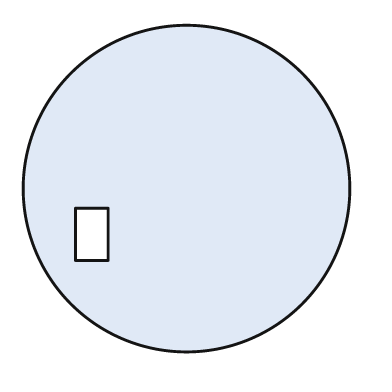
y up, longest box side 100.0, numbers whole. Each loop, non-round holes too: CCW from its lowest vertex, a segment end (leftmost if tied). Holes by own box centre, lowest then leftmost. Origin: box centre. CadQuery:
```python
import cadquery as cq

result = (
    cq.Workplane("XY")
    .moveTo(0.0, 0.0)
    .circle(50.0)
    .moveTo(-34.0, -22.0)
    .lineTo(-24.0, -22.0)
    .lineTo(-24.0, -6.0)
    .lineTo(-34.0, -6.0)
    .close()
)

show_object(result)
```